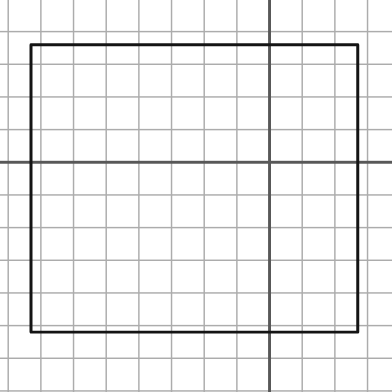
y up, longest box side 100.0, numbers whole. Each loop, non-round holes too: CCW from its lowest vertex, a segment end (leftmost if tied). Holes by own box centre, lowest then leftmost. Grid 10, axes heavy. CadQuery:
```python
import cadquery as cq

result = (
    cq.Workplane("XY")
    .moveTo(-73.0, -52.0)
    .lineTo(27.0, -52.0)
    .lineTo(27.0, 36.0)
    .lineTo(-73.0, 36.0)
    .close()
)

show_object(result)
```